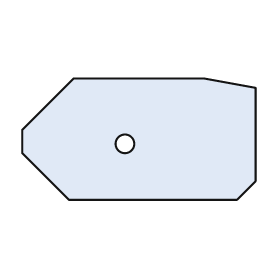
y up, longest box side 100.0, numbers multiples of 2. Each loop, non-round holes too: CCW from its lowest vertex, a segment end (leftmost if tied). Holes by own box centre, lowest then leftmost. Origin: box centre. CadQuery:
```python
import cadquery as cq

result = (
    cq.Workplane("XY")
    .moveTo(-30.0, -26.0)
    .lineTo(42.0, -26.0)
    .lineTo(50.0, -18.0)
    .lineTo(50.0, 22.0)
    .lineTo(28.0, 26.0)
    .lineTo(-28.0, 26.0)
    .lineTo(-50.0, 4.0)
    .lineTo(-50.0, -6.0)
    .close()
    .moveTo(-6.0, -2.0)
    .circle(4.0)
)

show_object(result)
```